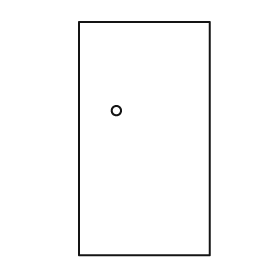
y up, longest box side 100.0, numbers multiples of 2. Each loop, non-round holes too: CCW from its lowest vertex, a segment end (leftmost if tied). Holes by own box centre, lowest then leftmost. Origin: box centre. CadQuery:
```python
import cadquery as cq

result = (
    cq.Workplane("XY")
    .moveTo(-28.0, -50.0)
    .lineTo(28.0, -50.0)
    .lineTo(28.0, 50.0)
    .lineTo(-28.0, 50.0)
    .close()
    .moveTo(-12.0, 12.0)
    .circle(2.0)
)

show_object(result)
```